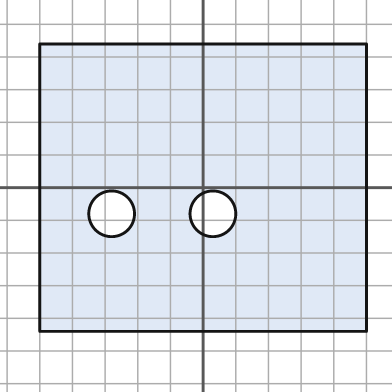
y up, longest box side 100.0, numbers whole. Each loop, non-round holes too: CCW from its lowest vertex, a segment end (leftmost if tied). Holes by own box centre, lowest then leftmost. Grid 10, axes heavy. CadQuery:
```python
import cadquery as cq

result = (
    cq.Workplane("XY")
    .moveTo(-50.0, -44.0)
    .lineTo(50.0, -44.0)
    .lineTo(50.0, 44.0)
    .lineTo(-50.0, 44.0)
    .close()
    .moveTo(-28.0, -8.0)
    .circle(7.0)
    .moveTo(3.0, -8.0)
    .circle(7.0)
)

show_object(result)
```